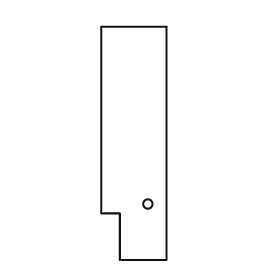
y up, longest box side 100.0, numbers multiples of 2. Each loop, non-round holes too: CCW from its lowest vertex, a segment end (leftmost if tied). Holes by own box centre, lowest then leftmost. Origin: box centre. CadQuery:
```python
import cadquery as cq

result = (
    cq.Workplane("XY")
    .moveTo(-6.0, -50.0)
    .lineTo(14.0, -50.0)
    .lineTo(14.0, 50.0)
    .lineTo(-14.0, 50.0)
    .lineTo(-14.0, -30.0)
    .lineTo(-6.0, -30.0)
    .close()
    .moveTo(6.0, -26.0)
    .circle(2.0)
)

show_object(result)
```